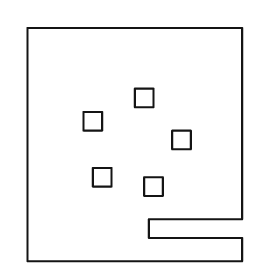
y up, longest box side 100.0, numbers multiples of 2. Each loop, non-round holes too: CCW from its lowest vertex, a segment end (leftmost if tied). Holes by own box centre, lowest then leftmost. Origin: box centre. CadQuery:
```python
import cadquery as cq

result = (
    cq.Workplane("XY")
    .moveTo(-46.0, -50.0)
    .lineTo(46.0, -50.0)
    .lineTo(46.0, -40.0)
    .lineTo(6.0, -40.0)
    .lineTo(6.0, -32.0)
    .lineTo(46.0, -32.0)
    .lineTo(46.0, 50.0)
    .lineTo(-46.0, 50.0)
    .close()
    .moveTo(4.0, -22.0)
    .lineTo(12.0, -22.0)
    .lineTo(12.0, -14.0)
    .lineTo(4.0, -14.0)
    .close()
    .moveTo(-18.0, -18.0)
    .lineTo(-10.0, -18.0)
    .lineTo(-10.0, -10.0)
    .lineTo(-18.0, -10.0)
    .close()
    .moveTo(16.0, -2.0)
    .lineTo(24.0, -2.0)
    .lineTo(24.0, 6.0)
    .lineTo(16.0, 6.0)
    .close()
    .moveTo(-22.0, 6.0)
    .lineTo(-14.0, 6.0)
    .lineTo(-14.0, 14.0)
    .lineTo(-22.0, 14.0)
    .close()
    .moveTo(0.0, 16.0)
    .lineTo(8.0, 16.0)
    .lineTo(8.0, 24.0)
    .lineTo(0.0, 24.0)
    .close()
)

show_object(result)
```